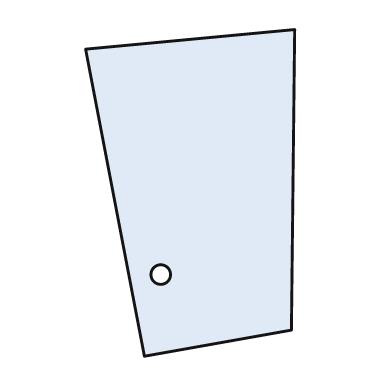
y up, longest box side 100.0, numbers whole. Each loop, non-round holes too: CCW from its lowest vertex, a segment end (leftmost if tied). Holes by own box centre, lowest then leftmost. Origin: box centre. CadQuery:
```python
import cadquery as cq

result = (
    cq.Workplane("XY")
    .moveTo(-14.0, -50.0)
    .lineTo(31.0, -42.0)
    .lineTo(32.0, 50.0)
    .lineTo(-32.0, 44.0)
    .close()
    .moveTo(-9.0, -25.0)
    .circle(3.0)
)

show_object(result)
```